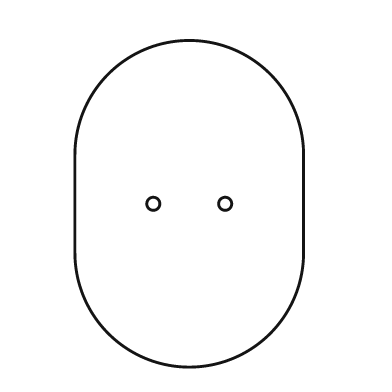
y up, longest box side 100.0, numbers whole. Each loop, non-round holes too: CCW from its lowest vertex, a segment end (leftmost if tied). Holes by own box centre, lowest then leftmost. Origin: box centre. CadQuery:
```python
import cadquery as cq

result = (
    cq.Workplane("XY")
    .moveTo(-35.0, -15.0)
    .threePointArc((0.0, -50.0), (35.0, -15.0))
    .lineTo(35.0, 15.0)
    .threePointArc((0.0, 50.0), (-35.0, 15.0))
    .close()
    .moveTo(-11.0, 0.0)
    .circle(2.0)
    .moveTo(11.0, 0.0)
    .circle(2.0)
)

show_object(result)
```